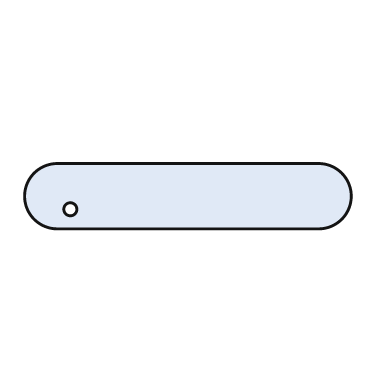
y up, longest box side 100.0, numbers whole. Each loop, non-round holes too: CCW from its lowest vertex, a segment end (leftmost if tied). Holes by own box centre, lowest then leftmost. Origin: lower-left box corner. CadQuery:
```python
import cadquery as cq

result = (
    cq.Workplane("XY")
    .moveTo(10.0, 0.0)
    .lineTo(90.0, 0.0)
    .threePointArc((100.0, 10.0), (90.0, 20.0))
    .lineTo(10.0, 20.0)
    .threePointArc((0.0, 10.0), (10.0, 0.0))
    .close()
    .moveTo(14.0, 6.0)
    .circle(2.0)
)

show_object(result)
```